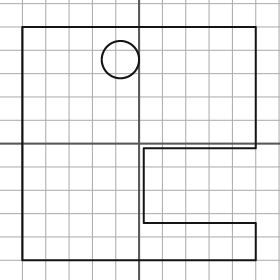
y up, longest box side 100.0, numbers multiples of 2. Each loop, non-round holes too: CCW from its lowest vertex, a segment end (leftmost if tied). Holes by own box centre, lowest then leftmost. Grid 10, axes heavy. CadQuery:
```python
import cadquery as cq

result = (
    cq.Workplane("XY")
    .moveTo(-50.0, -50.0)
    .lineTo(50.0, -50.0)
    .lineTo(50.0, -34.0)
    .lineTo(2.0, -34.0)
    .lineTo(2.0, -2.0)
    .lineTo(50.0, -2.0)
    .lineTo(50.0, 50.0)
    .lineTo(-50.0, 50.0)
    .close()
    .moveTo(-8.0, 36.0)
    .circle(8.0)
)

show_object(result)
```